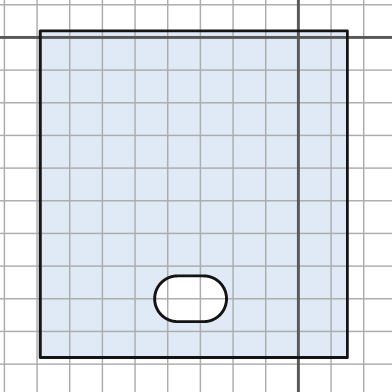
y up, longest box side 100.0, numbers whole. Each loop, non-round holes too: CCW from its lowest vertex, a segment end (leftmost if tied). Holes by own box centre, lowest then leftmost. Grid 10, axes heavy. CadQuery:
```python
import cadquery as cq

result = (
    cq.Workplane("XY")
    .moveTo(-79.0, -98.0)
    .lineTo(15.0, -98.0)
    .lineTo(15.0, 2.0)
    .lineTo(-79.0, 2.0)
    .close()
    .moveTo(-37.0, -87.0)
    .lineTo(-29.0, -87.0)
    .threePointArc((-22.0, -80.0), (-29.0, -73.0))
    .lineTo(-37.0, -73.0)
    .threePointArc((-44.0, -80.0), (-37.0, -87.0))
    .close()
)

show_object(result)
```